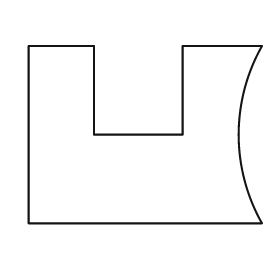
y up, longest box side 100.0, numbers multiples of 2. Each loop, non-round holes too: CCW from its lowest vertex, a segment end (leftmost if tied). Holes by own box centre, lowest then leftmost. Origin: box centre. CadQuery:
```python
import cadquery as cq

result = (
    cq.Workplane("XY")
    .moveTo(-50.0, -38.0)
    .lineTo(50.0, -38.0)
    .threePointArc((40.0, 0.0), (50.0, 38.0))
    .lineTo(16.0, 38.0)
    .lineTo(16.0, 0.0)
    .lineTo(-22.0, 0.0)
    .lineTo(-22.0, 38.0)
    .lineTo(-50.0, 38.0)
    .close()
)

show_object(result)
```